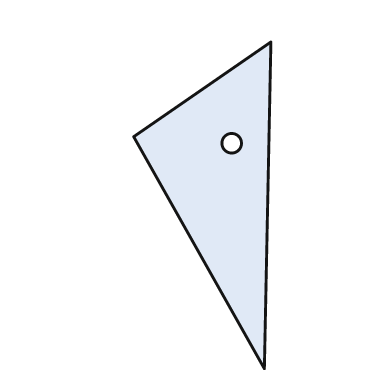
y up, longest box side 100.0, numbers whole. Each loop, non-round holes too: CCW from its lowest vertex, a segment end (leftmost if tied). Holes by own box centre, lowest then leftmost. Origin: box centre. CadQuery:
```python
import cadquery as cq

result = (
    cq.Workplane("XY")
    .moveTo(19.0, -50.0)
    .lineTo(21.0, 50.0)
    .lineTo(-21.0, 21.0)
    .close()
    .moveTo(9.0, 19.0)
    .circle(3.0)
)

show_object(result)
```